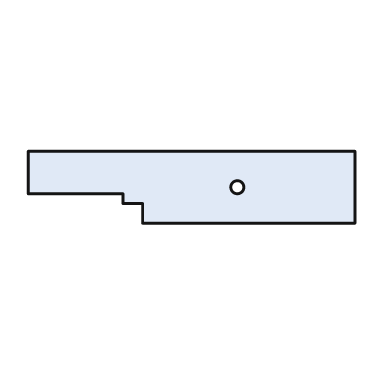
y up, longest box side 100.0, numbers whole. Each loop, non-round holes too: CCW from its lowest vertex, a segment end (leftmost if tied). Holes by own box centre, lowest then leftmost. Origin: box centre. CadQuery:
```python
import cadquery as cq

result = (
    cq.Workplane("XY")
    .moveTo(-15.0, -11.0)
    .lineTo(50.0, -11.0)
    .lineTo(50.0, 11.0)
    .lineTo(-50.0, 11.0)
    .lineTo(-50.0, -2.0)
    .lineTo(-21.0, -2.0)
    .lineTo(-21.0, -5.0)
    .lineTo(-15.0, -5.0)
    .close()
    .moveTo(14.0, 0.0)
    .circle(2.0)
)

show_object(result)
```